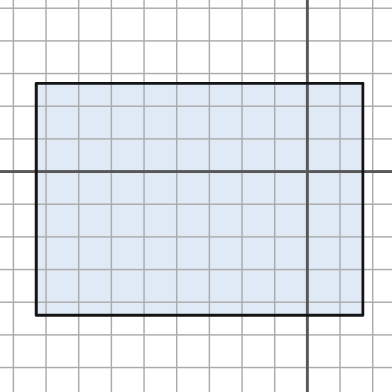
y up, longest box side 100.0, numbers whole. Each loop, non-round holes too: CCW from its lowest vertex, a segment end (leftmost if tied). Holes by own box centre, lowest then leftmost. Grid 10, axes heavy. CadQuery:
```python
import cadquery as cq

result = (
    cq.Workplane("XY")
    .moveTo(-83.0, -44.0)
    .lineTo(17.0, -44.0)
    .lineTo(17.0, 27.0)
    .lineTo(-83.0, 27.0)
    .close()
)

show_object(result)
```